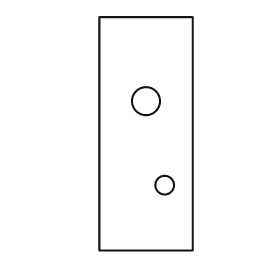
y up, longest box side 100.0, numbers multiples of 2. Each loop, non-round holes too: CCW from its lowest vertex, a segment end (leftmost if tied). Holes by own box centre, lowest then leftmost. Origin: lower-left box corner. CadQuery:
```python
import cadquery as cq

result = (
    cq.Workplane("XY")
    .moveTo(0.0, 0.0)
    .lineTo(40.0, 0.0)
    .lineTo(40.0, 100.0)
    .lineTo(0.0, 100.0)
    .close()
    .moveTo(28.0, 28.0)
    .circle(4.0)
    .moveTo(20.0, 64.0)
    .circle(6.0)
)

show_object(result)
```